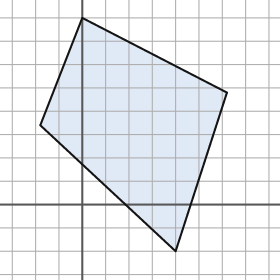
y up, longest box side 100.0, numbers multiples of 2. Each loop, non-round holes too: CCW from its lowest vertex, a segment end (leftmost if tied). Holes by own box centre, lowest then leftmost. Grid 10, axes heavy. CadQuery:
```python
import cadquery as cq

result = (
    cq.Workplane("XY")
    .moveTo(40.0, -20.0)
    .lineTo(62.0, 48.0)
    .lineTo(0.0, 80.0)
    .lineTo(-18.0, 34.0)
    .close()
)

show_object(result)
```